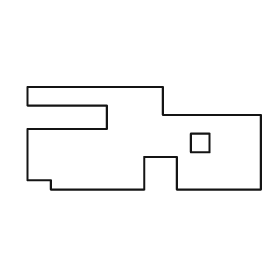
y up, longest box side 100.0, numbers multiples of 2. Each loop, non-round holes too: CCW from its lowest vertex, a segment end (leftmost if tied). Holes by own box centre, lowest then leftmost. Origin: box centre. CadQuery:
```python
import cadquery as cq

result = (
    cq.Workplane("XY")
    .moveTo(-40.0, -22.0)
    .lineTo(0.0, -22.0)
    .lineTo(0.0, -8.0)
    .lineTo(14.0, -8.0)
    .lineTo(14.0, -22.0)
    .lineTo(50.0, -22.0)
    .lineTo(50.0, 10.0)
    .lineTo(8.0, 10.0)
    .lineTo(8.0, 22.0)
    .lineTo(-50.0, 22.0)
    .lineTo(-50.0, 14.0)
    .lineTo(-16.0, 14.0)
    .lineTo(-16.0, 4.0)
    .lineTo(-50.0, 4.0)
    .lineTo(-50.0, -18.0)
    .lineTo(-40.0, -18.0)
    .close()
    .moveTo(20.0, -6.0)
    .lineTo(28.0, -6.0)
    .lineTo(28.0, 2.0)
    .lineTo(20.0, 2.0)
    .close()
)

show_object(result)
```